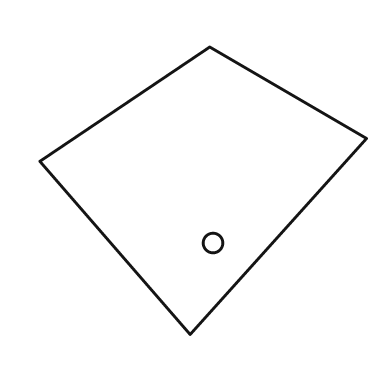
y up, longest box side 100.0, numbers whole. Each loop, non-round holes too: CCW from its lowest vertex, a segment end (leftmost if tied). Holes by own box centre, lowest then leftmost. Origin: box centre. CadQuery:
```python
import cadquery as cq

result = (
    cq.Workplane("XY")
    .moveTo(-4.0, -44.0)
    .lineTo(50.0, 16.0)
    .lineTo(2.0, 44.0)
    .lineTo(-50.0, 9.0)
    .close()
    .moveTo(3.0, -16.0)
    .circle(3.0)
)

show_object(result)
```